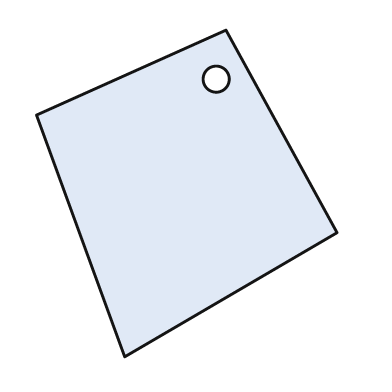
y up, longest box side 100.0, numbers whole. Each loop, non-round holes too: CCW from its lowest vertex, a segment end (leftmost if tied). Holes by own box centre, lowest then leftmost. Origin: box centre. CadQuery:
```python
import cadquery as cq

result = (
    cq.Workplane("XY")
    .moveTo(-19.0, -50.0)
    .lineTo(46.0, -12.0)
    .lineTo(12.0, 50.0)
    .lineTo(-46.0, 24.0)
    .close()
    .moveTo(9.0, 35.0)
    .circle(4.0)
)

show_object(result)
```